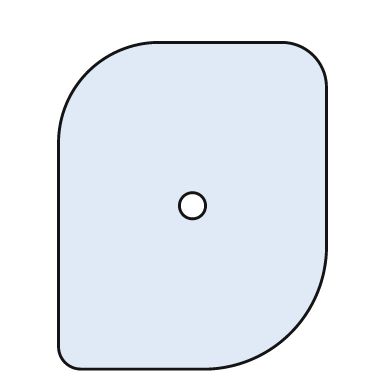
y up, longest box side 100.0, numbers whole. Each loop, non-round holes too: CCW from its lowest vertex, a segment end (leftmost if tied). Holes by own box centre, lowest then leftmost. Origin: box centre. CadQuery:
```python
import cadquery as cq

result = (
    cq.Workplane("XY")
    .moveTo(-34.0, -50.0)
    .lineTo(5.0, -50.0)
    .threePointArc((30.0, -39.0), (41.0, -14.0))
    .lineTo(41.0, 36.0)
    .threePointArc((37.0, 46.0), (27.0, 50.0))
    .lineTo(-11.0, 50.0)
    .threePointArc((-32.0, 41.0), (-41.0, 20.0))
    .lineTo(-41.0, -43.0)
    .threePointArc((-39.0, -48.0), (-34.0, -50.0))
    .close()
    .moveTo(0.0, 0.0)
    .circle(4.0)
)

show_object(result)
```